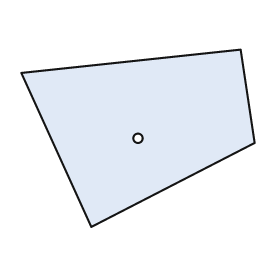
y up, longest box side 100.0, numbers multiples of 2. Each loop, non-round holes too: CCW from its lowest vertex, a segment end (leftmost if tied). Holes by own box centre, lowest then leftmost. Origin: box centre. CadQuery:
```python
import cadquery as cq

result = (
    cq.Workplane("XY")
    .moveTo(-20.0, -38.0)
    .lineTo(50.0, -2.0)
    .lineTo(44.0, 38.0)
    .lineTo(-50.0, 28.0)
    .close()
    .moveTo(0.0, 0.0)
    .circle(2.0)
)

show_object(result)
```